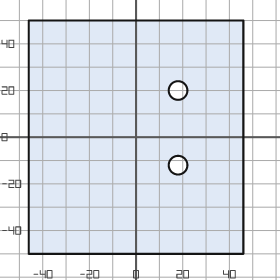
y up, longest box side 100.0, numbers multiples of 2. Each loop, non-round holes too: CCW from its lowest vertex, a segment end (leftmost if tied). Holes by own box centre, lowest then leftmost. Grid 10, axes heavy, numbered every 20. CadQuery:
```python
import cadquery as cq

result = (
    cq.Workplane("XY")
    .moveTo(-46.0, -50.0)
    .lineTo(46.0, -50.0)
    .lineTo(46.0, 50.0)
    .lineTo(-46.0, 50.0)
    .close()
    .moveTo(18.0, -12.0)
    .circle(4.0)
    .moveTo(18.0, 20.0)
    .circle(4.0)
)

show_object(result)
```